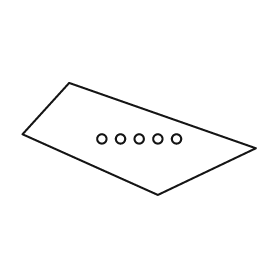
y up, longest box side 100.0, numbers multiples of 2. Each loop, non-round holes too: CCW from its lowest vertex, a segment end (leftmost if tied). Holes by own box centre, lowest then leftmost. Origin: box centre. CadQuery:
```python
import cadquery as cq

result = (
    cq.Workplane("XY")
    .moveTo(8.0, -24.0)
    .lineTo(50.0, -4.0)
    .lineTo(-30.0, 24.0)
    .lineTo(-50.0, 2.0)
    .close()
    .moveTo(-16.0, 0.0)
    .circle(2.0)
    .moveTo(-8.0, 0.0)
    .circle(2.0)
    .moveTo(0.0, 0.0)
    .circle(2.0)
    .moveTo(8.0, 0.0)
    .circle(2.0)
    .moveTo(16.0, 0.0)
    .circle(2.0)
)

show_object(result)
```